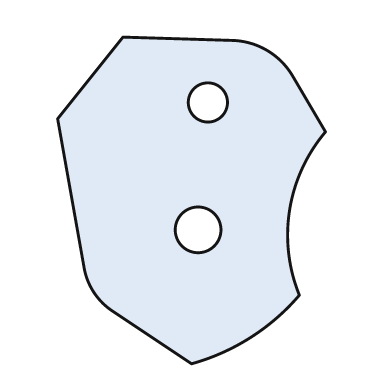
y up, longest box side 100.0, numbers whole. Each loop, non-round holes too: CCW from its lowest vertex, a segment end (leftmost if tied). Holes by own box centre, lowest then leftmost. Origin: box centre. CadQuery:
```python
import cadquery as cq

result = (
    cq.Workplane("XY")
    .moveTo(0.0, -50.0)
    .threePointArc((18.0, -42.0), (33.0, -29.0))
    .threePointArc((30.0, -3.0), (41.0, 21.0))
    .lineTo(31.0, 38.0)
    .threePointArc((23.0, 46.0), (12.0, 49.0))
    .lineTo(-21.0, 50.0)
    .lineTo(-41.0, 25.0)
    .lineTo(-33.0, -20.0)
    .threePointArc((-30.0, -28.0), (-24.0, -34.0))
    .close()
    .moveTo(2.0, -9.0)
    .circle(7.0)
    .moveTo(5.0, 30.0)
    .circle(6.0)
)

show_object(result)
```